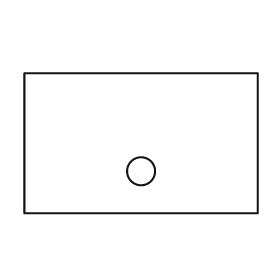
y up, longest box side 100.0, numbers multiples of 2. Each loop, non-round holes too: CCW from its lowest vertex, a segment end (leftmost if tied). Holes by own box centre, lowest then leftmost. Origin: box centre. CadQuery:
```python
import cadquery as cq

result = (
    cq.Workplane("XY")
    .moveTo(-50.0, -30.0)
    .lineTo(50.0, -30.0)
    .lineTo(50.0, 30.0)
    .lineTo(-50.0, 30.0)
    .close()
    .moveTo(0.0, -12.0)
    .circle(6.0)
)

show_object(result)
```